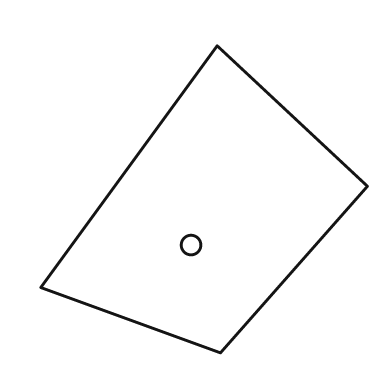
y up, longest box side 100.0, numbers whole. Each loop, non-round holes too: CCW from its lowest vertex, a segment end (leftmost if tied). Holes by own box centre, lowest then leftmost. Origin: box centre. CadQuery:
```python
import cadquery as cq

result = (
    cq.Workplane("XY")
    .moveTo(5.0, -47.0)
    .lineTo(50.0, 4.0)
    .lineTo(4.0, 47.0)
    .lineTo(-50.0, -27.0)
    .close()
    .moveTo(-4.0, -14.0)
    .circle(3.0)
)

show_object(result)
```